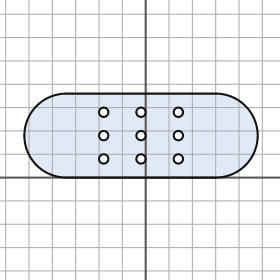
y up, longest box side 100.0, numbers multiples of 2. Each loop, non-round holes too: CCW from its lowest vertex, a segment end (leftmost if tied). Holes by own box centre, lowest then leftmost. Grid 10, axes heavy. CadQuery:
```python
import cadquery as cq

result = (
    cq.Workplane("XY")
    .moveTo(-34.0, 0.0)
    .lineTo(30.0, 0.0)
    .threePointArc((48.0, 18.0), (30.0, 36.0))
    .lineTo(-34.0, 36.0)
    .threePointArc((-52.0, 18.0), (-34.0, 0.0))
    .close()
    .moveTo(-18.0, 8.0)
    .circle(2.0)
    .moveTo(-2.0, 8.0)
    .circle(2.0)
    .moveTo(14.0, 8.0)
    .circle(2.0)
    .moveTo(-18.0, 18.0)
    .circle(2.0)
    .moveTo(-2.0, 18.0)
    .circle(2.0)
    .moveTo(14.0, 18.0)
    .circle(2.0)
    .moveTo(-18.0, 28.0)
    .circle(2.0)
    .moveTo(-2.0, 28.0)
    .circle(2.0)
    .moveTo(14.0, 28.0)
    .circle(2.0)
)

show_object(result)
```